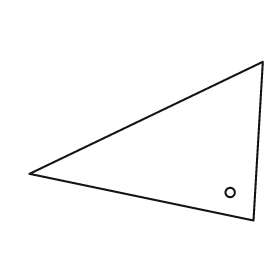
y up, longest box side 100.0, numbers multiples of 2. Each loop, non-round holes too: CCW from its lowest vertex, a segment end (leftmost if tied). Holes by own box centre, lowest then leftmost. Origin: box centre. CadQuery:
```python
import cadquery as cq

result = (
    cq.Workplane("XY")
    .moveTo(46.0, -34.0)
    .lineTo(50.0, 34.0)
    .lineTo(-50.0, -14.0)
    .close()
    .moveTo(36.0, -22.0)
    .circle(2.0)
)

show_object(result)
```